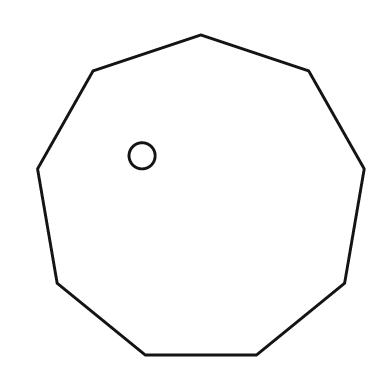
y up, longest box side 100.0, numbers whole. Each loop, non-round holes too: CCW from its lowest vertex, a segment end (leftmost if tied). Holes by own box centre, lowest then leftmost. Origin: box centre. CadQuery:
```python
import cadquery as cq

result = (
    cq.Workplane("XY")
    .moveTo(-17.0, -49.0)
    .lineTo(17.0, -49.0)
    .lineTo(44.0, -27.0)
    .lineTo(50.0, 8.0)
    .lineTo(33.0, 38.0)
    .lineTo(0.0, 49.0)
    .lineTo(-33.0, 38.0)
    .lineTo(-50.0, 8.0)
    .lineTo(-44.0, -27.0)
    .close()
    .moveTo(-18.0, 12.0)
    .circle(4.0)
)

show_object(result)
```